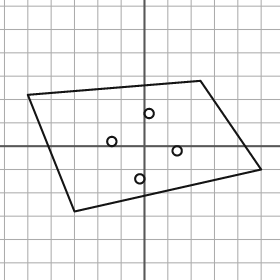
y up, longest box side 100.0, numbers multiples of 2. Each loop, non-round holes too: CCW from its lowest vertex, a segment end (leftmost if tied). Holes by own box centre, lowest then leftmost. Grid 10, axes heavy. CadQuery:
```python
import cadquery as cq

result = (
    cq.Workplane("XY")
    .moveTo(-30.0, -28.0)
    .lineTo(50.0, -10.0)
    .lineTo(24.0, 28.0)
    .lineTo(-50.0, 22.0)
    .close()
    .moveTo(-2.0, -14.0)
    .circle(2.0)
    .moveTo(14.0, -2.0)
    .circle(2.0)
    .moveTo(-14.0, 2.0)
    .circle(2.0)
    .moveTo(2.0, 14.0)
    .circle(2.0)
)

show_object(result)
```